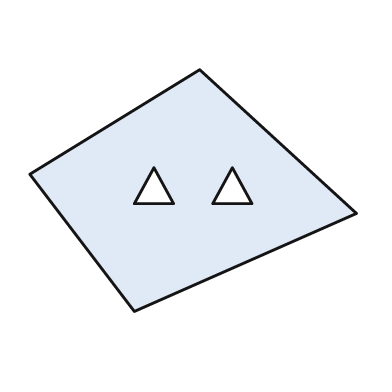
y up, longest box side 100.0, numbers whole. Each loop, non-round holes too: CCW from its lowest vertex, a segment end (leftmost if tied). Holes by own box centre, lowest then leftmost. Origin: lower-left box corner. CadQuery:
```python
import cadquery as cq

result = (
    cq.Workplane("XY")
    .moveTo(32.0, 0.0)
    .lineTo(100.0, 30.0)
    .lineTo(52.0, 74.0)
    .lineTo(0.0, 42.0)
    .close()
    .moveTo(32.0, 33.0)
    .lineTo(44.0, 33.0)
    .lineTo(38.0, 44.0)
    .close()
    .moveTo(56.0, 33.0)
    .lineTo(68.0, 33.0)
    .lineTo(62.0, 44.0)
    .close()
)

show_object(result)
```